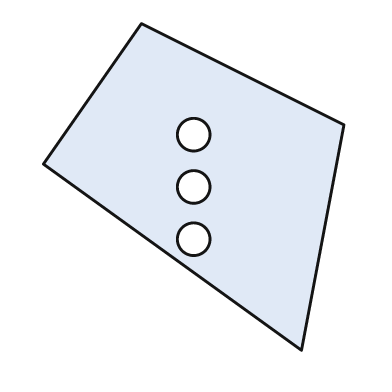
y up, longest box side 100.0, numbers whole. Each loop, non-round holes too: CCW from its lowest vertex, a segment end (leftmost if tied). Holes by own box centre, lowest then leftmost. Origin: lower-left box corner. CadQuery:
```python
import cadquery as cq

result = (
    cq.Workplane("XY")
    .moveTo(79.0, 0.0)
    .lineTo(92.0, 69.0)
    .lineTo(30.0, 100.0)
    .lineTo(0.0, 57.0)
    .close()
    .moveTo(46.0, 34.0)
    .circle(5.0)
    .moveTo(46.0, 50.0)
    .circle(5.0)
    .moveTo(46.0, 66.0)
    .circle(5.0)
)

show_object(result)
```